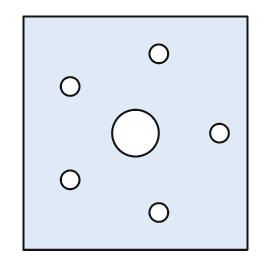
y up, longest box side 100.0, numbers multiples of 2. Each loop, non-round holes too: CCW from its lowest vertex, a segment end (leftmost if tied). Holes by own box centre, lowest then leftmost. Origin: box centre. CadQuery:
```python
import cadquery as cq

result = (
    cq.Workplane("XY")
    .moveTo(-48.0, -50.0)
    .lineTo(48.0, -50.0)
    .lineTo(48.0, 50.0)
    .lineTo(-48.0, 50.0)
    .close()
    .moveTo(10.0, -34.0)
    .circle(4.0)
    .moveTo(-28.0, -20.0)
    .circle(4.0)
    .moveTo(0.0, 0.0)
    .circle(10.0)
    .moveTo(36.0, 0.0)
    .circle(4.0)
    .moveTo(-28.0, 20.0)
    .circle(4.0)
    .moveTo(10.0, 34.0)
    .circle(4.0)
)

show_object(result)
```